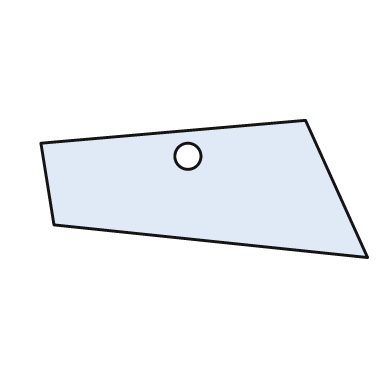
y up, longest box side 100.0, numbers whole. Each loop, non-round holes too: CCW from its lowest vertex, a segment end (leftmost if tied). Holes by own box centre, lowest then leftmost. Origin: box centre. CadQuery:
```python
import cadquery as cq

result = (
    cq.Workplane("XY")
    .moveTo(50.0, -21.0)
    .lineTo(31.0, 21.0)
    .lineTo(-50.0, 14.0)
    .lineTo(-46.0, -11.0)
    .close()
    .moveTo(-5.0, 10.0)
    .circle(4.0)
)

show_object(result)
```